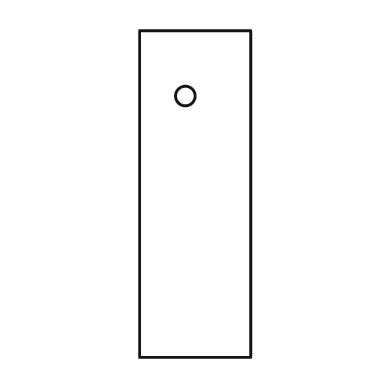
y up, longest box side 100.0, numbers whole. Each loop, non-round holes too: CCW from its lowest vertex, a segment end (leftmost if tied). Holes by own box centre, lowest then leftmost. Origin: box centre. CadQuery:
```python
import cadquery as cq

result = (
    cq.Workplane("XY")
    .moveTo(-17.0, -50.0)
    .lineTo(17.0, -50.0)
    .lineTo(17.0, 50.0)
    .lineTo(-17.0, 50.0)
    .close()
    .moveTo(-3.0, 30.0)
    .circle(3.0)
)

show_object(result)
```